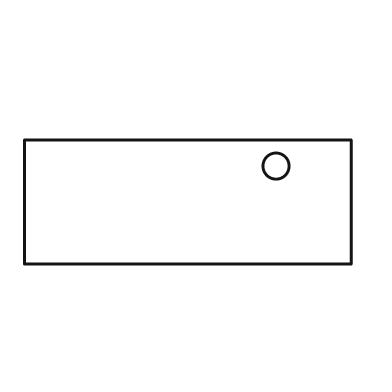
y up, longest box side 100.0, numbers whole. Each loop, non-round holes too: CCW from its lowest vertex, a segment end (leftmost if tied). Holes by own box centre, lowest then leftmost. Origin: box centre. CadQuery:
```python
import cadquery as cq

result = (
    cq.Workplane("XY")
    .moveTo(-50.0, -19.0)
    .lineTo(50.0, -19.0)
    .lineTo(50.0, 19.0)
    .lineTo(-50.0, 19.0)
    .close()
    .moveTo(27.0, 11.0)
    .circle(4.0)
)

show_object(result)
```